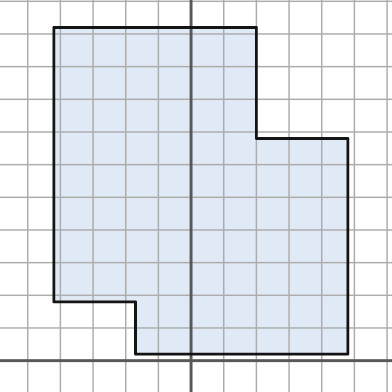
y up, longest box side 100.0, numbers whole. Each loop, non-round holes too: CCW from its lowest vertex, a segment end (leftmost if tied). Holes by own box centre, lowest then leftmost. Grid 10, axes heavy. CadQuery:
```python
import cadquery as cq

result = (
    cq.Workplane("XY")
    .moveTo(-17.0, 2.0)
    .lineTo(48.0, 2.0)
    .lineTo(48.0, 68.0)
    .lineTo(20.0, 68.0)
    .lineTo(20.0, 102.0)
    .lineTo(-42.0, 102.0)
    .lineTo(-42.0, 18.0)
    .lineTo(-17.0, 18.0)
    .close()
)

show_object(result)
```